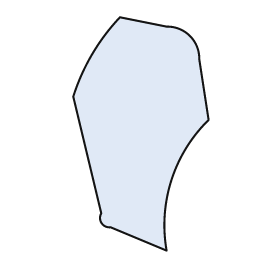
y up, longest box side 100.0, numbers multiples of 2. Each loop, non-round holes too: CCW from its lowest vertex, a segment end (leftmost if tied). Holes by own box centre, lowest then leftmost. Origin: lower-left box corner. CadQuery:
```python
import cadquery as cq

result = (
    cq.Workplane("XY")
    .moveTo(40.0, 0.0)
    .threePointArc((42.0, 30.0), (58.0, 56.0))
    .lineTo(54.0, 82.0)
    .threePointArc((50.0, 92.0), (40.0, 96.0))
    .lineTo(20.0, 100.0)
    .threePointArc((8.0, 84.0), (0.0, 66.0))
    .lineTo(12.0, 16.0)
    .threePointArc((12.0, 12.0), (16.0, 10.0))
    .close()
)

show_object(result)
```